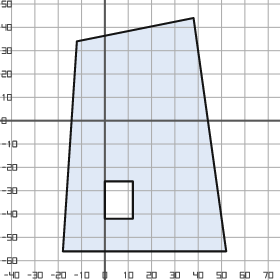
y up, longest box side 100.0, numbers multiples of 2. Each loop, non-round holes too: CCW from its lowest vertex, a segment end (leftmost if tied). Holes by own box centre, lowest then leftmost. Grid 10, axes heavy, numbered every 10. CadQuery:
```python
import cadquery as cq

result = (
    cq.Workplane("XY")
    .moveTo(-18.0, -56.0)
    .lineTo(52.0, -56.0)
    .lineTo(38.0, 44.0)
    .lineTo(-12.0, 34.0)
    .close()
    .moveTo(0.0, -42.0)
    .lineTo(12.0, -42.0)
    .lineTo(12.0, -26.0)
    .lineTo(0.0, -26.0)
    .close()
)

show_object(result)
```